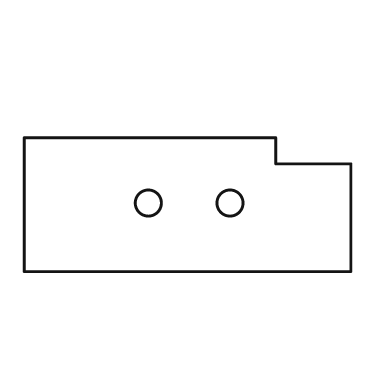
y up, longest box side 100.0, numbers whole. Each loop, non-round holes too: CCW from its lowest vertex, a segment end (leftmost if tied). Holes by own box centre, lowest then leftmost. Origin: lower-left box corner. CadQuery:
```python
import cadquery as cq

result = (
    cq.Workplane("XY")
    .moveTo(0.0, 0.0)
    .lineTo(100.0, 0.0)
    .lineTo(100.0, 33.0)
    .lineTo(77.0, 33.0)
    .lineTo(77.0, 41.0)
    .lineTo(0.0, 41.0)
    .close()
    .moveTo(38.0, 21.0)
    .circle(4.0)
    .moveTo(63.0, 21.0)
    .circle(4.0)
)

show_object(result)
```